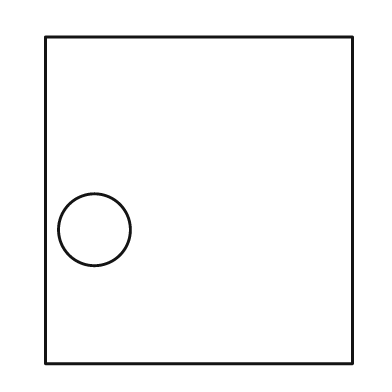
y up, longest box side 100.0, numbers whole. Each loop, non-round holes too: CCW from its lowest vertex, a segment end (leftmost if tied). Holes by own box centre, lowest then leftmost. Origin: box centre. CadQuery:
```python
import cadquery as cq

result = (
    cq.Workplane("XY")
    .moveTo(-47.0, -50.0)
    .lineTo(47.0, -50.0)
    .lineTo(47.0, 50.0)
    .lineTo(-47.0, 50.0)
    .close()
    .moveTo(-32.0, -9.0)
    .circle(11.0)
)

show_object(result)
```